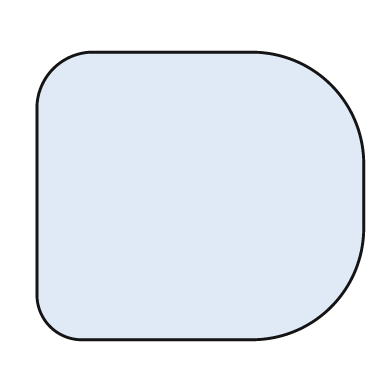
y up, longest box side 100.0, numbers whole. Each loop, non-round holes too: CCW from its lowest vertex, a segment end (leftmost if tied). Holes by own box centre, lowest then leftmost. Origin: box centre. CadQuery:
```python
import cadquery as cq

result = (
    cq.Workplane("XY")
    .moveTo(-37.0, -44.0)
    .lineTo(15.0, -44.0)
    .threePointArc((40.0, -34.0), (50.0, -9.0))
    .lineTo(50.0, 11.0)
    .threePointArc((40.0, 34.0), (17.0, 44.0))
    .lineTo(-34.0, 44.0)
    .threePointArc((-45.0, 39.0), (-50.0, 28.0))
    .lineTo(-50.0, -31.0)
    .threePointArc((-46.0, -40.0), (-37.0, -44.0))
    .close()
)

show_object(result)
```